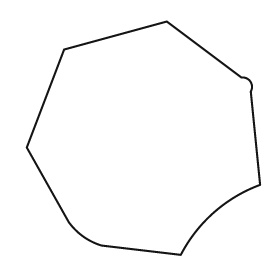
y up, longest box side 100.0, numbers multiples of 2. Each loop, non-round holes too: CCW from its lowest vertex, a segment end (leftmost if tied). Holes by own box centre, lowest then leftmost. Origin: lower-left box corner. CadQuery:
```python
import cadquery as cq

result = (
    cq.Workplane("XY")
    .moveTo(66.0, 0.0)
    .threePointArc((80.0, 18.0), (100.0, 30.0))
    .lineTo(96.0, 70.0)
    .threePointArc((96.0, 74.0), (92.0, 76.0))
    .lineTo(60.0, 100.0)
    .lineTo(16.0, 88.0)
    .lineTo(0.0, 46.0)
    .lineTo(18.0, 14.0)
    .threePointArc((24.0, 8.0), (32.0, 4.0))
    .close()
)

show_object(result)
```